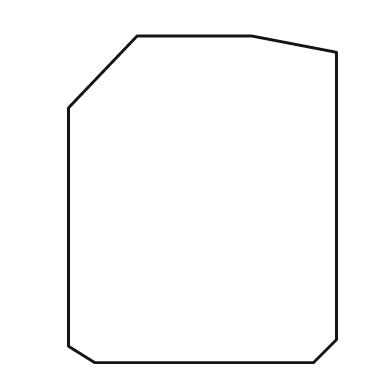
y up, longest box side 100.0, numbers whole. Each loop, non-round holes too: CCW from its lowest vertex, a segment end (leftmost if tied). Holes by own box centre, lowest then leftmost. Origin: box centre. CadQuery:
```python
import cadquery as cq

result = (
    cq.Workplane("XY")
    .moveTo(-33.0, -50.0)
    .lineTo(34.0, -50.0)
    .lineTo(41.0, -43.0)
    .lineTo(41.0, 45.0)
    .lineTo(15.0, 50.0)
    .lineTo(-20.0, 50.0)
    .lineTo(-41.0, 28.0)
    .lineTo(-41.0, -45.0)
    .close()
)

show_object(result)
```